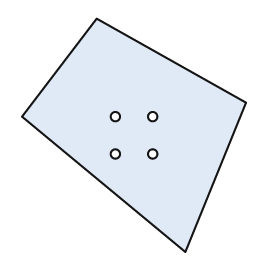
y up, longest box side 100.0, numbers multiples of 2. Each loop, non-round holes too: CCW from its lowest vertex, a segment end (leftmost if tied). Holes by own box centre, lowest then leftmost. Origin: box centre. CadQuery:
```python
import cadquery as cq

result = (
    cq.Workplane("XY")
    .moveTo(22.0, -50.0)
    .lineTo(48.0, 14.0)
    .lineTo(-16.0, 50.0)
    .lineTo(-48.0, 8.0)
    .close()
    .moveTo(-8.0, -8.0)
    .circle(2.0)
    .moveTo(8.0, -8.0)
    .circle(2.0)
    .moveTo(-8.0, 8.0)
    .circle(2.0)
    .moveTo(8.0, 8.0)
    .circle(2.0)
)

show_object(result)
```